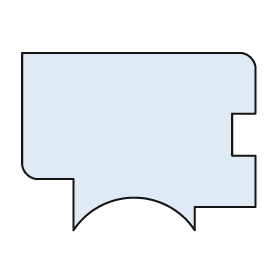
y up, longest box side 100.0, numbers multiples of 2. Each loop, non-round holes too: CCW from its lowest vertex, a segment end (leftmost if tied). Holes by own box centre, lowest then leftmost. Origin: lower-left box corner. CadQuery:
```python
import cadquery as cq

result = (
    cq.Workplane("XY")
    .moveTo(22.0, 0.0)
    .threePointArc((48.0, 14.0), (74.0, 0.0))
    .lineTo(74.0, 10.0)
    .lineTo(100.0, 10.0)
    .lineTo(100.0, 32.0)
    .lineTo(90.0, 32.0)
    .lineTo(90.0, 50.0)
    .lineTo(100.0, 50.0)
    .lineTo(100.0, 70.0)
    .threePointArc((98.0, 74.0), (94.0, 76.0))
    .lineTo(0.0, 76.0)
    .lineTo(0.0, 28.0)
    .threePointArc((2.0, 24.0), (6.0, 22.0))
    .lineTo(22.0, 22.0)
    .close()
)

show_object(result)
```